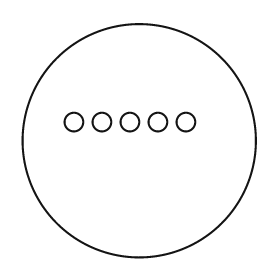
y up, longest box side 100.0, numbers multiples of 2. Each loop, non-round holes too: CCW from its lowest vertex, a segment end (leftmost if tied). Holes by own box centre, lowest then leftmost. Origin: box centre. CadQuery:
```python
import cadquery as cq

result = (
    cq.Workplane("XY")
    .moveTo(0.0, 0.0)
    .circle(50.0)
    .moveTo(-28.0, 8.0)
    .circle(4.0)
    .moveTo(-16.0, 8.0)
    .circle(4.0)
    .moveTo(-4.0, 8.0)
    .circle(4.0)
    .moveTo(8.0, 8.0)
    .circle(4.0)
    .moveTo(20.0, 8.0)
    .circle(4.0)
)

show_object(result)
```